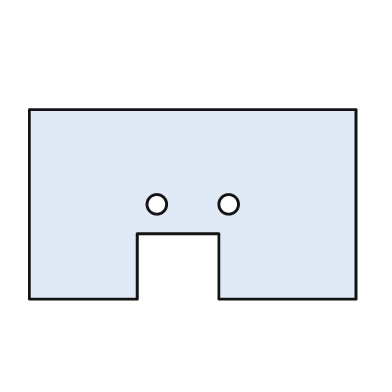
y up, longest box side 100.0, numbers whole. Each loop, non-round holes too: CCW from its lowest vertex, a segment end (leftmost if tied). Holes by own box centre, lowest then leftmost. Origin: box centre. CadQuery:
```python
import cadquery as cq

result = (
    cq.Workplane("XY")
    .moveTo(-50.0, -29.0)
    .lineTo(-17.0, -29.0)
    .lineTo(-17.0, -9.0)
    .lineTo(8.0, -9.0)
    .lineTo(8.0, -29.0)
    .lineTo(50.0, -29.0)
    .lineTo(50.0, 29.0)
    .lineTo(-50.0, 29.0)
    .close()
    .moveTo(-11.0, 0.0)
    .circle(3.0)
    .moveTo(11.0, 0.0)
    .circle(3.0)
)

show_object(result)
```